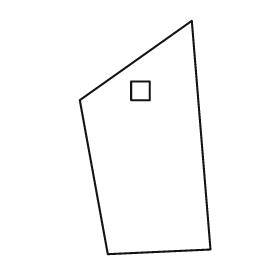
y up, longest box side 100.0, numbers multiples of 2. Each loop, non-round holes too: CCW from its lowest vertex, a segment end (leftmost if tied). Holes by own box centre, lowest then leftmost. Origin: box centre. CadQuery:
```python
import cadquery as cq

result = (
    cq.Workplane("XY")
    .moveTo(-16.0, -50.0)
    .lineTo(28.0, -48.0)
    .lineTo(20.0, 50.0)
    .lineTo(-28.0, 16.0)
    .close()
    .moveTo(-6.0, 16.0)
    .lineTo(2.0, 16.0)
    .lineTo(2.0, 24.0)
    .lineTo(-6.0, 24.0)
    .close()
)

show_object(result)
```